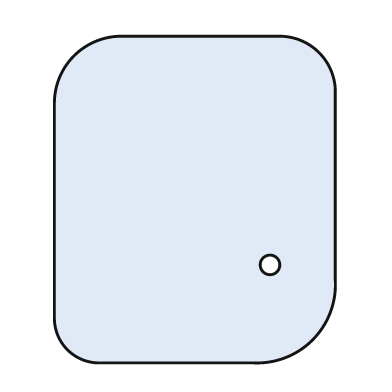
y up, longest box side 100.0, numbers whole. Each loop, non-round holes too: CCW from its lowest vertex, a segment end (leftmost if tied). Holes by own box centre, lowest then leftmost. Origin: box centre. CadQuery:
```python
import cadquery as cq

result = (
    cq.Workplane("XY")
    .moveTo(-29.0, -50.0)
    .lineTo(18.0, -50.0)
    .threePointArc((36.0, -43.0), (43.0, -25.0))
    .lineTo(43.0, 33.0)
    .threePointArc((38.0, 45.0), (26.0, 50.0))
    .lineTo(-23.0, 50.0)
    .threePointArc((-37.0, 44.0), (-43.0, 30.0))
    .lineTo(-43.0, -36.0)
    .threePointArc((-39.0, -46.0), (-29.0, -50.0))
    .close()
    .moveTo(23.0, -20.0)
    .circle(3.0)
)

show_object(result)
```